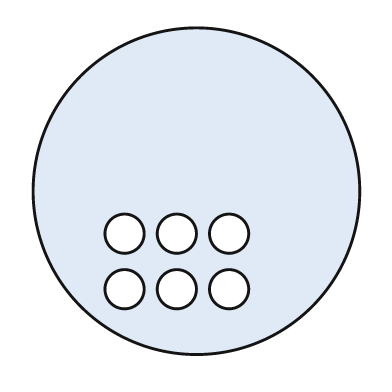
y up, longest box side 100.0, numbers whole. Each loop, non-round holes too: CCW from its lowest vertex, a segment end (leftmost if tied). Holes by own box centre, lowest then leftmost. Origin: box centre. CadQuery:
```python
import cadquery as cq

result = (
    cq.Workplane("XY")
    .moveTo(0.0, 0.0)
    .circle(50.0)
    .moveTo(-22.0, -30.0)
    .circle(6.0)
    .moveTo(-6.0, -30.0)
    .circle(6.0)
    .moveTo(10.0, -30.0)
    .circle(6.0)
    .moveTo(-22.0, -13.0)
    .circle(6.0)
    .moveTo(-6.0, -13.0)
    .circle(6.0)
    .moveTo(10.0, -13.0)
    .circle(6.0)
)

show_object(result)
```